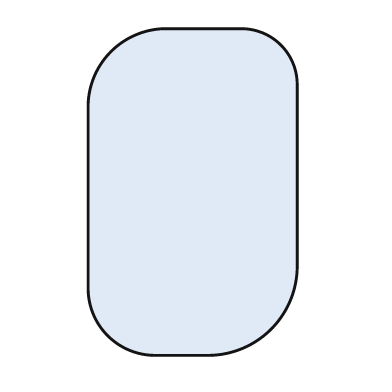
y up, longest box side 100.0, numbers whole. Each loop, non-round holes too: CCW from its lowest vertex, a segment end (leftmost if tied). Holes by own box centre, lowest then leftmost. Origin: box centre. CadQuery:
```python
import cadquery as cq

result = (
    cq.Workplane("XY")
    .moveTo(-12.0, -50.0)
    .lineTo(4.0, -50.0)
    .threePointArc((24.0, -42.0), (32.0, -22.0))
    .lineTo(32.0, 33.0)
    .threePointArc((27.0, 45.0), (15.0, 50.0))
    .lineTo(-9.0, 50.0)
    .threePointArc((-25.0, 43.0), (-32.0, 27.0))
    .lineTo(-32.0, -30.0)
    .threePointArc((-26.0, -44.0), (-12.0, -50.0))
    .close()
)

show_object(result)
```